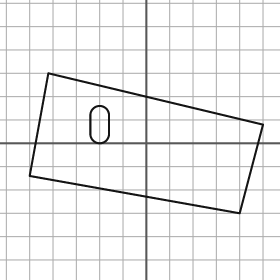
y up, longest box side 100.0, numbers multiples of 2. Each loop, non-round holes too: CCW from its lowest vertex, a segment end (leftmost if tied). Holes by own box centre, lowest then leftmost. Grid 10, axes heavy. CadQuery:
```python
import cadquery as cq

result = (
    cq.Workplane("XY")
    .moveTo(40.0, -30.0)
    .lineTo(50.0, 8.0)
    .lineTo(-42.0, 30.0)
    .lineTo(-50.0, -14.0)
    .close()
    .moveTo(-24.0, 4.0)
    .threePointArc((-20.0, 0.0), (-16.0, 4.0))
    .lineTo(-16.0, 12.0)
    .threePointArc((-20.0, 16.0), (-24.0, 12.0))
    .close()
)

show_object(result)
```